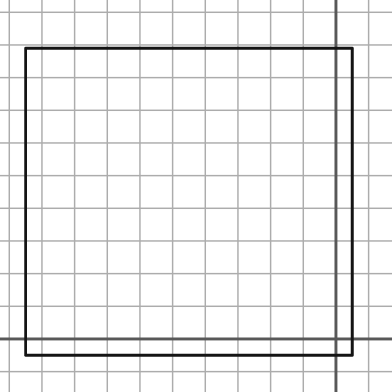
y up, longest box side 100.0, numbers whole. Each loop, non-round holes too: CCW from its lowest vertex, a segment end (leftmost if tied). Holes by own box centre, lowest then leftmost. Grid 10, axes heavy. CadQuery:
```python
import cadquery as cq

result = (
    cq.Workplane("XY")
    .moveTo(-95.0, -5.0)
    .lineTo(5.0, -5.0)
    .lineTo(5.0, 89.0)
    .lineTo(-95.0, 89.0)
    .close()
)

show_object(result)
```